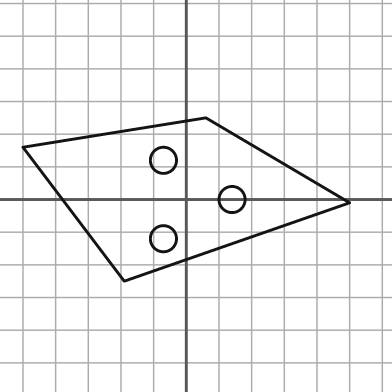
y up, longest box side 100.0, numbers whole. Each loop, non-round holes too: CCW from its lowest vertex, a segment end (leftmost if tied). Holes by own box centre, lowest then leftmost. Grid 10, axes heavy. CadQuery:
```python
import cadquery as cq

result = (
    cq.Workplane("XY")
    .moveTo(-19.0, -25.0)
    .lineTo(50.0, -1.0)
    .lineTo(6.0, 25.0)
    .lineTo(-50.0, 16.0)
    .close()
    .moveTo(-7.0, -12.0)
    .circle(4.0)
    .moveTo(14.0, 0.0)
    .circle(4.0)
    .moveTo(-7.0, 12.0)
    .circle(4.0)
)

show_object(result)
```